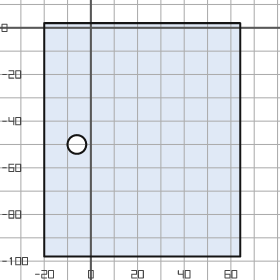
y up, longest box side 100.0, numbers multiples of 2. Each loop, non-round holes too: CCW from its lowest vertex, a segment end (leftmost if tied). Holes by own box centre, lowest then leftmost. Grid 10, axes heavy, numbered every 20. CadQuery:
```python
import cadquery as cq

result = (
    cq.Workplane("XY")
    .moveTo(-20.0, -98.0)
    .lineTo(64.0, -98.0)
    .lineTo(64.0, 2.0)
    .lineTo(-20.0, 2.0)
    .close()
    .moveTo(-6.0, -50.0)
    .circle(4.0)
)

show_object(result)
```